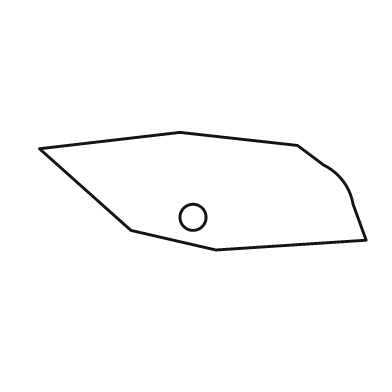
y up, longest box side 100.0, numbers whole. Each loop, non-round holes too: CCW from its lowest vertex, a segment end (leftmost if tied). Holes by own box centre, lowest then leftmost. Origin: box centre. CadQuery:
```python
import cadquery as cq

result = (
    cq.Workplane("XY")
    .moveTo(4.0, -18.0)
    .lineTo(50.0, -15.0)
    .lineTo(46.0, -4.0)
    .threePointArc((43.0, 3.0), (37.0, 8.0))
    .lineTo(29.0, 14.0)
    .lineTo(-7.0, 18.0)
    .lineTo(-50.0, 13.0)
    .lineTo(-22.0, -12.0)
    .close()
    .moveTo(-3.0, -8.0)
    .circle(4.0)
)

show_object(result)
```